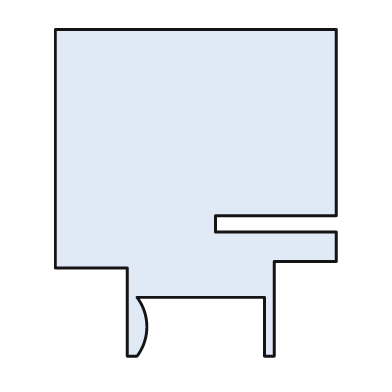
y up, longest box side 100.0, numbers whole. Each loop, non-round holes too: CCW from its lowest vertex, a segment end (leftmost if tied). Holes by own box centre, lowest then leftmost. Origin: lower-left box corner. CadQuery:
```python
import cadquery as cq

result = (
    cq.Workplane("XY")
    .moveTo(22.0, 0.0)
    .lineTo(25.0, 0.0)
    .threePointArc((28.0, 9.0), (25.0, 18.0))
    .lineTo(64.0, 18.0)
    .lineTo(64.0, 0.0)
    .lineTo(67.0, 0.0)
    .lineTo(67.0, 29.0)
    .lineTo(86.0, 29.0)
    .lineTo(86.0, 38.0)
    .lineTo(49.0, 38.0)
    .lineTo(49.0, 43.0)
    .lineTo(86.0, 43.0)
    .lineTo(86.0, 100.0)
    .lineTo(0.0, 100.0)
    .lineTo(0.0, 27.0)
    .lineTo(22.0, 27.0)
    .close()
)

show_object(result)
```